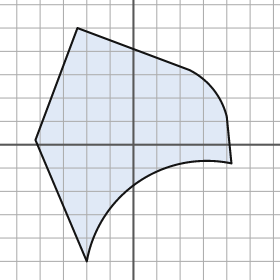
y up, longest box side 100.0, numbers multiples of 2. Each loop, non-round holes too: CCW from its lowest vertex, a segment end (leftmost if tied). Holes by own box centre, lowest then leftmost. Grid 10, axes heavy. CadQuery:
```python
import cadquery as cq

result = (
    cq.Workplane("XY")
    .moveTo(-20.0, -50.0)
    .threePointArc((2.0, -16.0), (42.0, -8.0))
    .lineTo(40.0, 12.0)
    .threePointArc((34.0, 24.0), (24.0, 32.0))
    .lineTo(-24.0, 50.0)
    .lineTo(-42.0, 2.0)
    .close()
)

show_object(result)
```